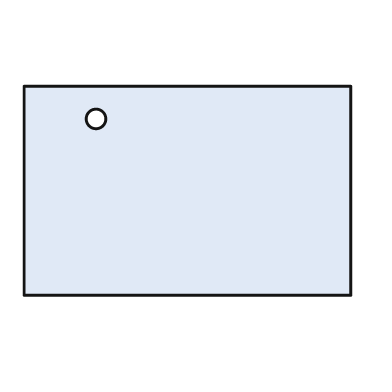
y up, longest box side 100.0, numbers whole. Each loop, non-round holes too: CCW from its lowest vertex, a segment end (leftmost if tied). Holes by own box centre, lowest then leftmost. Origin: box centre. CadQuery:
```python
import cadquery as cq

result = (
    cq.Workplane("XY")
    .moveTo(-50.0, -32.0)
    .lineTo(50.0, -32.0)
    .lineTo(50.0, 32.0)
    .lineTo(-50.0, 32.0)
    .close()
    .moveTo(-28.0, 22.0)
    .circle(3.0)
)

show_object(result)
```